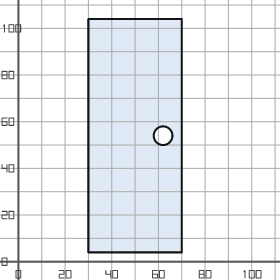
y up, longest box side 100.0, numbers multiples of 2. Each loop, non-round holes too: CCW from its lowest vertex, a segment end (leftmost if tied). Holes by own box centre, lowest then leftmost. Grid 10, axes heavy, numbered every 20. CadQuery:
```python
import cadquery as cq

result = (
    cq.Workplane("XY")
    .moveTo(30.0, 4.0)
    .lineTo(70.0, 4.0)
    .lineTo(70.0, 104.0)
    .lineTo(30.0, 104.0)
    .close()
    .moveTo(62.0, 54.0)
    .circle(4.0)
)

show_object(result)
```